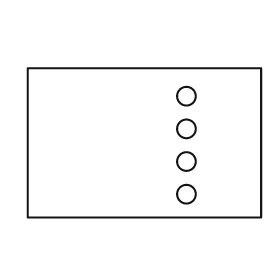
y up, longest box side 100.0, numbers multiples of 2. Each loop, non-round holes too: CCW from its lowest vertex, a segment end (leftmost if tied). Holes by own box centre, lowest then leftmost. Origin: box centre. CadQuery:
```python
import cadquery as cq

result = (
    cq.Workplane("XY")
    .moveTo(-50.0, -32.0)
    .lineTo(50.0, -32.0)
    .lineTo(50.0, 32.0)
    .lineTo(-50.0, 32.0)
    .close()
    .moveTo(18.0, -22.0)
    .circle(4.0)
    .moveTo(18.0, -8.0)
    .circle(4.0)
    .moveTo(18.0, 6.0)
    .circle(4.0)
    .moveTo(18.0, 20.0)
    .circle(4.0)
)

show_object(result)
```